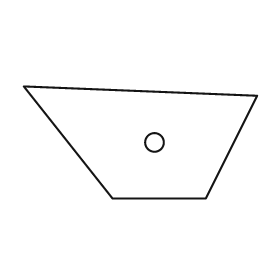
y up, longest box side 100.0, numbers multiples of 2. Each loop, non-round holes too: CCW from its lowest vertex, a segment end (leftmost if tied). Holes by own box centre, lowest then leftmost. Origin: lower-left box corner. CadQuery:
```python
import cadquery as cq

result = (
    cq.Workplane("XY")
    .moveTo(38.0, 0.0)
    .lineTo(78.0, 0.0)
    .lineTo(100.0, 44.0)
    .lineTo(0.0, 48.0)
    .close()
    .moveTo(56.0, 24.0)
    .circle(4.0)
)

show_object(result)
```